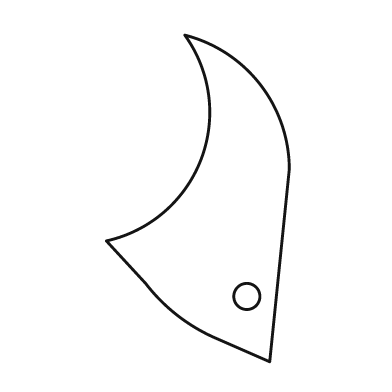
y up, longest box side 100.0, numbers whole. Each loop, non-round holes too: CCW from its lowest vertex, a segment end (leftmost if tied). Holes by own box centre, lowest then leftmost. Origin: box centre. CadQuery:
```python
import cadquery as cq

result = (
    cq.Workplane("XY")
    .moveTo(22.0, -50.0)
    .lineTo(28.0, 9.0)
    .threePointArc((19.0, 35.0), (-4.0, 50.0))
    .threePointArc((1.0, 12.0), (-28.0, -13.0))
    .lineTo(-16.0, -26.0)
    .threePointArc((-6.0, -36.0), (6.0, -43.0))
    .close()
    .moveTo(15.0, -30.0)
    .circle(4.0)
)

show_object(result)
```